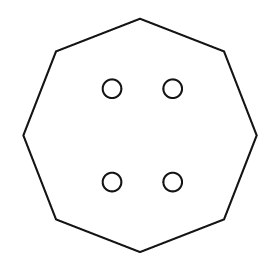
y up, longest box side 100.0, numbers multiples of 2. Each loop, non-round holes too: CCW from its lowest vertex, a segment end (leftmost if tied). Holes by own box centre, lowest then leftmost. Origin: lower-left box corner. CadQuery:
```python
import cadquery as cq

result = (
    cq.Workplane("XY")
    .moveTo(50.0, 0.0)
    .lineTo(86.0, 14.0)
    .lineTo(100.0, 50.0)
    .lineTo(86.0, 86.0)
    .lineTo(50.0, 100.0)
    .lineTo(14.0, 86.0)
    .lineTo(0.0, 50.0)
    .lineTo(14.0, 14.0)
    .close()
    .moveTo(38.0, 30.0)
    .circle(4.0)
    .moveTo(64.0, 30.0)
    .circle(4.0)
    .moveTo(38.0, 70.0)
    .circle(4.0)
    .moveTo(64.0, 70.0)
    .circle(4.0)
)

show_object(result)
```